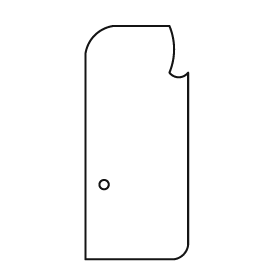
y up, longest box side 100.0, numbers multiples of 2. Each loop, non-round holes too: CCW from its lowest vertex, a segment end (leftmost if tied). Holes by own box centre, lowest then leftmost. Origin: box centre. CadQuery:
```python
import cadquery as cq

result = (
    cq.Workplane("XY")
    .moveTo(-22.0, -50.0)
    .lineTo(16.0, -50.0)
    .threePointArc((20.0, -48.0), (22.0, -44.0))
    .lineTo(22.0, 30.0)
    .threePointArc((18.0, 28.0), (14.0, 30.0))
    .threePointArc((16.0, 40.0), (14.0, 50.0))
    .lineTo(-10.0, 50.0)
    .threePointArc((-18.0, 46.0), (-22.0, 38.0))
    .close()
    .moveTo(-14.0, -18.0)
    .circle(2.0)
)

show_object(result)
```